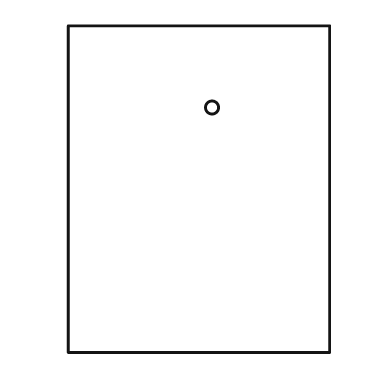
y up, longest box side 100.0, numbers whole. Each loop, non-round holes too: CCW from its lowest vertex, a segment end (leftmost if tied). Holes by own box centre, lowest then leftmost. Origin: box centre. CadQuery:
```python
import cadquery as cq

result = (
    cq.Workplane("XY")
    .moveTo(-40.0, -50.0)
    .lineTo(40.0, -50.0)
    .lineTo(40.0, 50.0)
    .lineTo(-40.0, 50.0)
    .close()
    .moveTo(4.0, 25.0)
    .circle(2.0)
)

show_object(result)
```